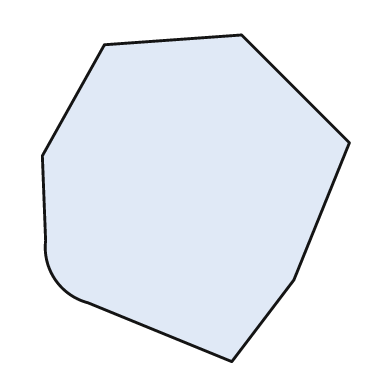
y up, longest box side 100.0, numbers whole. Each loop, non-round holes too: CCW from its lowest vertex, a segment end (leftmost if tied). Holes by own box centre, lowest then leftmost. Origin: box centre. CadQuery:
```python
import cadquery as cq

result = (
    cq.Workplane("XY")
    .moveTo(11.0, -50.0)
    .lineTo(30.0, -25.0)
    .lineTo(47.0, 17.0)
    .lineTo(14.0, 50.0)
    .lineTo(-28.0, 47.0)
    .lineTo(-47.0, 13.0)
    .lineTo(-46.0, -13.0)
    .threePointArc((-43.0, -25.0), (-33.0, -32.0))
    .close()
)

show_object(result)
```